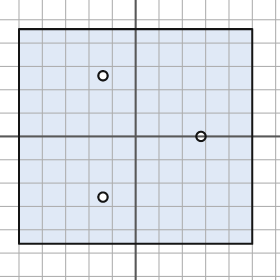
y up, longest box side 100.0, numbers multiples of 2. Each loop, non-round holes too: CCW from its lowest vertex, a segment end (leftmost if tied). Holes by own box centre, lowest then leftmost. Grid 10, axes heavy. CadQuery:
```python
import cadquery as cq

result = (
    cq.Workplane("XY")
    .moveTo(-50.0, -46.0)
    .lineTo(50.0, -46.0)
    .lineTo(50.0, 46.0)
    .lineTo(-50.0, 46.0)
    .close()
    .moveTo(-14.0, -26.0)
    .circle(2.0)
    .moveTo(28.0, 0.0)
    .circle(2.0)
    .moveTo(-14.0, 26.0)
    .circle(2.0)
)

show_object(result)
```